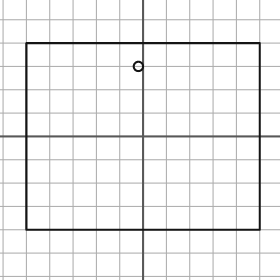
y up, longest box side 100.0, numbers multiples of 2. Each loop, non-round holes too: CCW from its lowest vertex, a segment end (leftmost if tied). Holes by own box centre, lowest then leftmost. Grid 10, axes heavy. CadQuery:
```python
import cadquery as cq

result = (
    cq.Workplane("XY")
    .moveTo(-50.0, -40.0)
    .lineTo(50.0, -40.0)
    .lineTo(50.0, 40.0)
    .lineTo(-50.0, 40.0)
    .close()
    .moveTo(-2.0, 30.0)
    .circle(2.0)
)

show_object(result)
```